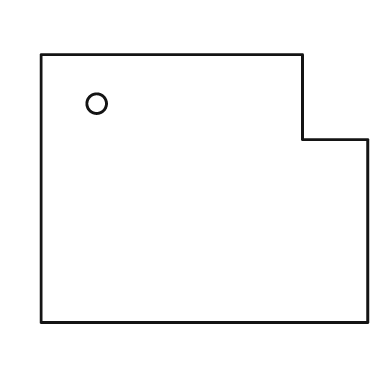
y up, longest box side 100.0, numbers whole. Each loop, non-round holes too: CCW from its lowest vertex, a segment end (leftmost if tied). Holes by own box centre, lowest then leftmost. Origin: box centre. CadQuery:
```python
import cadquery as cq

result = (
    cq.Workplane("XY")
    .moveTo(-50.0, -41.0)
    .lineTo(50.0, -41.0)
    .lineTo(50.0, 15.0)
    .lineTo(30.0, 15.0)
    .lineTo(30.0, 41.0)
    .lineTo(-50.0, 41.0)
    .close()
    .moveTo(-33.0, 26.0)
    .circle(3.0)
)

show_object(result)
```